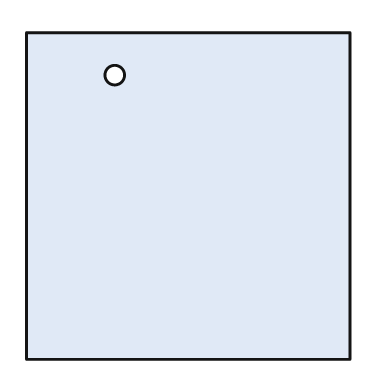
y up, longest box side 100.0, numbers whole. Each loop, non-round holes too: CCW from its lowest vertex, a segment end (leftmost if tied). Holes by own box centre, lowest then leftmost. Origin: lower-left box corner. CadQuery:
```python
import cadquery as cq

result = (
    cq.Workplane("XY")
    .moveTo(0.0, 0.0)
    .lineTo(99.0, 0.0)
    .lineTo(99.0, 100.0)
    .lineTo(0.0, 100.0)
    .close()
    .moveTo(27.0, 87.0)
    .circle(3.0)
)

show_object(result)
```